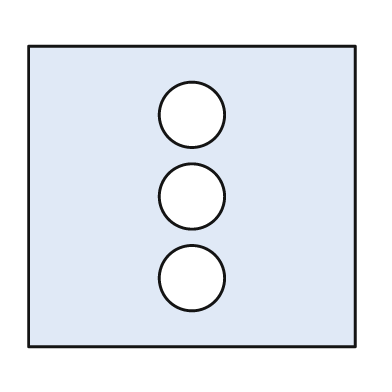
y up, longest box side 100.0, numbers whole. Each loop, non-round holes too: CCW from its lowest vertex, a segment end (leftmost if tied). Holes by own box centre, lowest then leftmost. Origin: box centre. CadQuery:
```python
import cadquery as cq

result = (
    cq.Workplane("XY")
    .moveTo(-50.0, -46.0)
    .lineTo(50.0, -46.0)
    .lineTo(50.0, 46.0)
    .lineTo(-50.0, 46.0)
    .close()
    .moveTo(0.0, -25.0)
    .circle(10.0)
    .moveTo(0.0, 0.0)
    .circle(10.0)
    .moveTo(0.0, 25.0)
    .circle(10.0)
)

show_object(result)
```